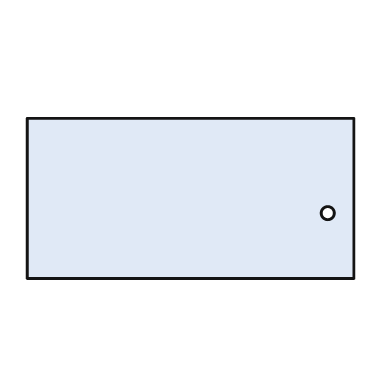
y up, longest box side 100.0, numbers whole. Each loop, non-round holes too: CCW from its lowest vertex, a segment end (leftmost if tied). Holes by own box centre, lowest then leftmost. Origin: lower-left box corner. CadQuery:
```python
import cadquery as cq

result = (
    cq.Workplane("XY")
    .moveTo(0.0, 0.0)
    .lineTo(100.0, 0.0)
    .lineTo(100.0, 49.0)
    .lineTo(0.0, 49.0)
    .close()
    .moveTo(92.0, 20.0)
    .circle(2.0)
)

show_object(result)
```